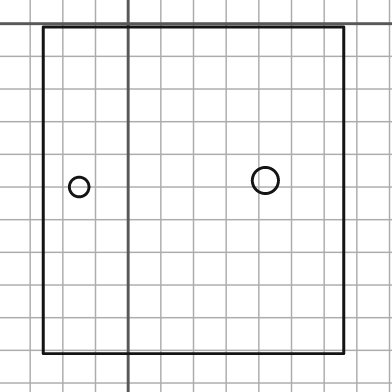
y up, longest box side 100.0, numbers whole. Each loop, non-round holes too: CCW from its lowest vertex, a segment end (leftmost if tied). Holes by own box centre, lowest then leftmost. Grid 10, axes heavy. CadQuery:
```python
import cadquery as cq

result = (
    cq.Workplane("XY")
    .moveTo(-26.0, -101.0)
    .lineTo(66.0, -101.0)
    .lineTo(66.0, -1.0)
    .lineTo(-26.0, -1.0)
    .close()
    .moveTo(-15.0, -50.0)
    .circle(3.0)
    .moveTo(42.0, -48.0)
    .circle(4.0)
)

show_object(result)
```